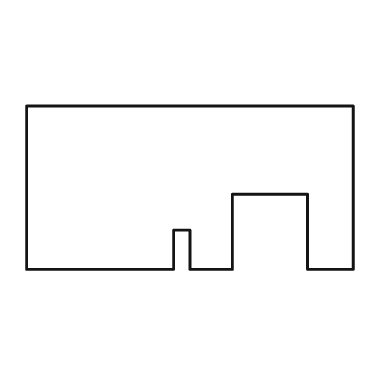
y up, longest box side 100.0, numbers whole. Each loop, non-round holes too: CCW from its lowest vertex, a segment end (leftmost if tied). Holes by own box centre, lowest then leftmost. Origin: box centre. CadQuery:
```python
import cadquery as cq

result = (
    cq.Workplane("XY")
    .moveTo(-50.0, -25.0)
    .lineTo(-5.0, -25.0)
    .lineTo(-5.0, -13.0)
    .lineTo(0.0, -13.0)
    .lineTo(0.0, -25.0)
    .lineTo(13.0, -25.0)
    .lineTo(13.0, -2.0)
    .lineTo(36.0, -2.0)
    .lineTo(36.0, -25.0)
    .lineTo(50.0, -25.0)
    .lineTo(50.0, 25.0)
    .lineTo(-50.0, 25.0)
    .close()
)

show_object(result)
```